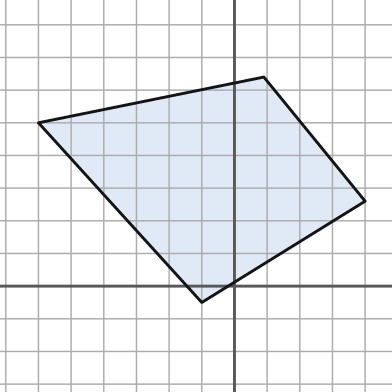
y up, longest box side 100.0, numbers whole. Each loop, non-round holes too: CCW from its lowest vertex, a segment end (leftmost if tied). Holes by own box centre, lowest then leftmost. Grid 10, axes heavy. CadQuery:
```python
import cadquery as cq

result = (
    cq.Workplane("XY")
    .moveTo(-10.0, -5.0)
    .lineTo(40.0, 26.0)
    .lineTo(9.0, 64.0)
    .lineTo(-60.0, 50.0)
    .close()
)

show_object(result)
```